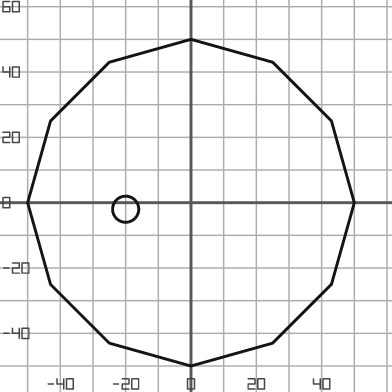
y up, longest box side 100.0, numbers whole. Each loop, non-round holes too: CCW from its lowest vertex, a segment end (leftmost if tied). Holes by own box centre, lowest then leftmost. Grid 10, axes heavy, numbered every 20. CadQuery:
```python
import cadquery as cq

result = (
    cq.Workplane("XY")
    .moveTo(0.0, -50.0)
    .lineTo(25.0, -43.0)
    .lineTo(43.0, -25.0)
    .lineTo(50.0, 0.0)
    .lineTo(43.0, 25.0)
    .lineTo(25.0, 43.0)
    .lineTo(0.0, 50.0)
    .lineTo(-25.0, 43.0)
    .lineTo(-43.0, 25.0)
    .lineTo(-50.0, 0.0)
    .lineTo(-43.0, -25.0)
    .lineTo(-25.0, -43.0)
    .close()
    .moveTo(-20.0, -2.0)
    .circle(4.0)
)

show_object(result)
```